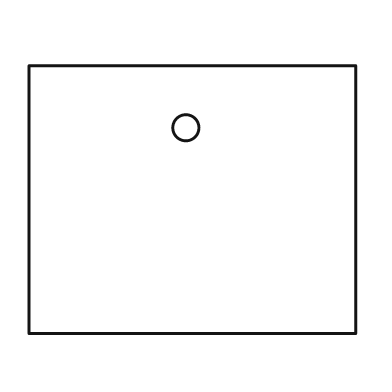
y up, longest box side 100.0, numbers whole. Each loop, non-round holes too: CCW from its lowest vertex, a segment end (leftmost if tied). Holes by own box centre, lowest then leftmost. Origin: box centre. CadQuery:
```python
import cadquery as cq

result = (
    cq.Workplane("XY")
    .moveTo(-50.0, -41.0)
    .lineTo(50.0, -41.0)
    .lineTo(50.0, 41.0)
    .lineTo(-50.0, 41.0)
    .close()
    .moveTo(-2.0, 22.0)
    .circle(4.0)
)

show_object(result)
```